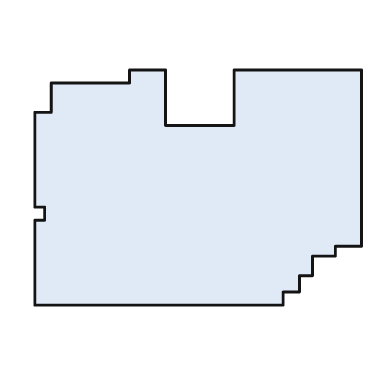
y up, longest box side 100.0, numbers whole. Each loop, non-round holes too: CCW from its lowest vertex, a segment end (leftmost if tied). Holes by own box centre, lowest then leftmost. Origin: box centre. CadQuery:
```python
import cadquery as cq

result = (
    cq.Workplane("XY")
    .moveTo(-50.0, -36.0)
    .lineTo(26.0, -36.0)
    .lineTo(26.0, -32.0)
    .lineTo(31.0, -32.0)
    .lineTo(31.0, -27.0)
    .lineTo(35.0, -27.0)
    .lineTo(35.0, -21.0)
    .lineTo(42.0, -21.0)
    .lineTo(42.0, -18.0)
    .lineTo(50.0, -18.0)
    .lineTo(50.0, 36.0)
    .lineTo(11.0, 36.0)
    .lineTo(11.0, 19.0)
    .lineTo(-10.0, 19.0)
    .lineTo(-10.0, 36.0)
    .lineTo(-21.0, 36.0)
    .lineTo(-21.0, 32.0)
    .lineTo(-45.0, 32.0)
    .lineTo(-45.0, 23.0)
    .lineTo(-50.0, 23.0)
    .lineTo(-50.0, -6.0)
    .lineTo(-47.0, -6.0)
    .lineTo(-47.0, -10.0)
    .lineTo(-50.0, -10.0)
    .close()
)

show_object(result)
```